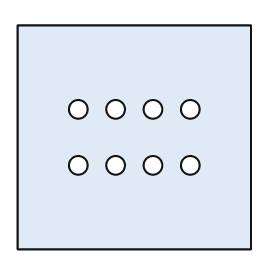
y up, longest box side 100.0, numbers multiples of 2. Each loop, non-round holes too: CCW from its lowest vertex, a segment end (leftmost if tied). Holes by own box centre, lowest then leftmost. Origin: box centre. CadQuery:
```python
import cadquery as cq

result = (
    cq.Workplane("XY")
    .moveTo(-50.0, -48.0)
    .lineTo(50.0, -48.0)
    .lineTo(50.0, 48.0)
    .lineTo(-50.0, 48.0)
    .close()
    .moveTo(-24.0, -12.0)
    .circle(4.0)
    .moveTo(-8.0, -12.0)
    .circle(4.0)
    .moveTo(8.0, -12.0)
    .circle(4.0)
    .moveTo(24.0, -12.0)
    .circle(4.0)
    .moveTo(-24.0, 12.0)
    .circle(4.0)
    .moveTo(-8.0, 12.0)
    .circle(4.0)
    .moveTo(8.0, 12.0)
    .circle(4.0)
    .moveTo(24.0, 12.0)
    .circle(4.0)
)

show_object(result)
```